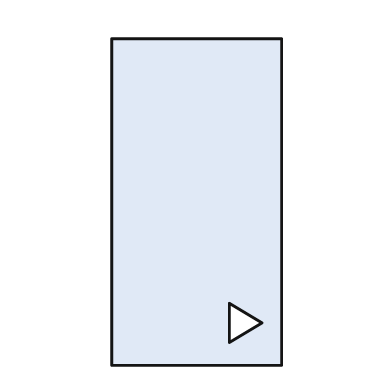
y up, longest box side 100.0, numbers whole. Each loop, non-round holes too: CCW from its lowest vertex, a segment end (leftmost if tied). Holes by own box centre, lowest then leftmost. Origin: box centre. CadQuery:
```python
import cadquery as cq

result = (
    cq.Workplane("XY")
    .moveTo(-26.0, -50.0)
    .lineTo(26.0, -50.0)
    .lineTo(26.0, 50.0)
    .lineTo(-26.0, 50.0)
    .close()
    .moveTo(10.0, -43.0)
    .lineTo(20.0, -37.0)
    .lineTo(10.0, -31.0)
    .close()
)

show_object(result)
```